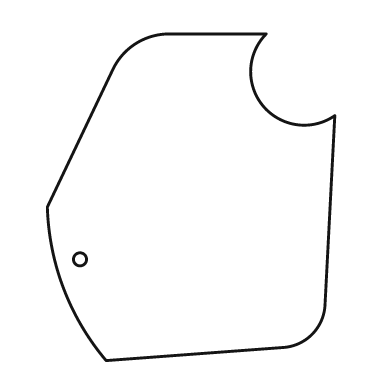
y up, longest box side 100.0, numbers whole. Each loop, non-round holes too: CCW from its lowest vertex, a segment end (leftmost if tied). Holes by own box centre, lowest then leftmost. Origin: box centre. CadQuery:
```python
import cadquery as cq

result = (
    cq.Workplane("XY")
    .moveTo(-26.0, -50.0)
    .lineTo(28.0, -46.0)
    .threePointArc((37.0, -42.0), (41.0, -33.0))
    .lineTo(44.0, 25.0)
    .threePointArc((22.0, 28.0), (23.0, 50.0))
    .lineTo(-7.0, 50.0)
    .threePointArc((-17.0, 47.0), (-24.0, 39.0))
    .lineTo(-44.0, -3.0)
    .threePointArc((-39.0, -28.0), (-26.0, -50.0))
    .close()
    .moveTo(-34.0, -19.0)
    .circle(2.0)
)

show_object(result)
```